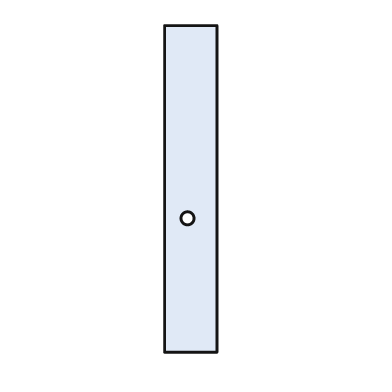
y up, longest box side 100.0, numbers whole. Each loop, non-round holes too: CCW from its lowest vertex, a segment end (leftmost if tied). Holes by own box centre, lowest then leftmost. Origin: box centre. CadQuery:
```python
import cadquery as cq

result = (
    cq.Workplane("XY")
    .moveTo(-8.0, -50.0)
    .lineTo(8.0, -50.0)
    .lineTo(8.0, 50.0)
    .lineTo(-8.0, 50.0)
    .close()
    .moveTo(-1.0, -9.0)
    .circle(2.0)
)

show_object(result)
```